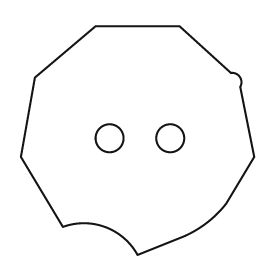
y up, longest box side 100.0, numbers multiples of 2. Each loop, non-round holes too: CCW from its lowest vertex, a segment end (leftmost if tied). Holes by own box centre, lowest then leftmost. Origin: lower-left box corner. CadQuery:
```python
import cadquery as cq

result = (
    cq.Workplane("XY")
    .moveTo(50.0, 0.0)
    .lineTo(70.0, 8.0)
    .threePointArc((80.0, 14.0), (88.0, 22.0))
    .lineTo(100.0, 42.0)
    .lineTo(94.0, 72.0)
    .threePointArc((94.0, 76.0), (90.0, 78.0))
    .lineTo(68.0, 98.0)
    .lineTo(32.0, 98.0)
    .lineTo(6.0, 76.0)
    .lineTo(0.0, 42.0)
    .lineTo(18.0, 12.0)
    .threePointArc((36.0, 12.0), (50.0, 0.0))
    .close()
    .moveTo(38.0, 50.0)
    .circle(6.0)
    .moveTo(64.0, 50.0)
    .circle(6.0)
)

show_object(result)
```